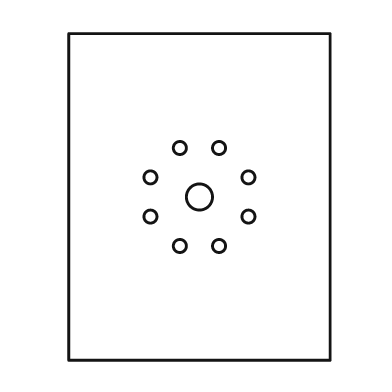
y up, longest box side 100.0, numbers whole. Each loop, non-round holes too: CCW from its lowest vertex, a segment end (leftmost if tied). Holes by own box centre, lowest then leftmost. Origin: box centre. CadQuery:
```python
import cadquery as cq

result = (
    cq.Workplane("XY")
    .moveTo(-40.0, -50.0)
    .lineTo(40.0, -50.0)
    .lineTo(40.0, 50.0)
    .lineTo(-40.0, 50.0)
    .close()
    .moveTo(-6.0, -15.0)
    .circle(2.0)
    .moveTo(6.0, -15.0)
    .circle(2.0)
    .moveTo(-15.0, -6.0)
    .circle(2.0)
    .moveTo(15.0, -6.0)
    .circle(2.0)
    .moveTo(0.0, 0.0)
    .circle(4.0)
    .moveTo(-15.0, 6.0)
    .circle(2.0)
    .moveTo(15.0, 6.0)
    .circle(2.0)
    .moveTo(-6.0, 15.0)
    .circle(2.0)
    .moveTo(6.0, 15.0)
    .circle(2.0)
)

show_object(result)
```